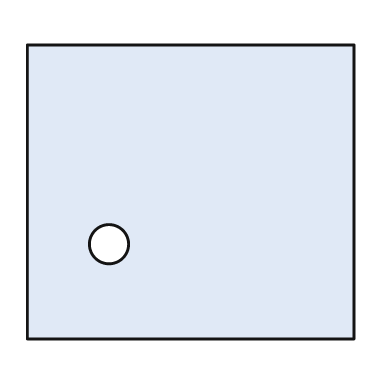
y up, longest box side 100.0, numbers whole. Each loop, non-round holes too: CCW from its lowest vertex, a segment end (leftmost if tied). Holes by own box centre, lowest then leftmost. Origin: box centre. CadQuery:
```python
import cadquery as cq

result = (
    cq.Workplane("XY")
    .moveTo(-50.0, -45.0)
    .lineTo(50.0, -45.0)
    .lineTo(50.0, 45.0)
    .lineTo(-50.0, 45.0)
    .close()
    .moveTo(-25.0, -16.0)
    .circle(6.0)
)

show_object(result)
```